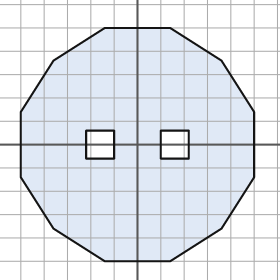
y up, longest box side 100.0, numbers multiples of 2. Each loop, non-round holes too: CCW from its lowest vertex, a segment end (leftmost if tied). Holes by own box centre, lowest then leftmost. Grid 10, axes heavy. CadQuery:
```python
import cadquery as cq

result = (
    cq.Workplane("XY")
    .moveTo(-14.0, -50.0)
    .lineTo(14.0, -50.0)
    .lineTo(36.0, -36.0)
    .lineTo(50.0, -14.0)
    .lineTo(50.0, 14.0)
    .lineTo(36.0, 36.0)
    .lineTo(14.0, 50.0)
    .lineTo(-14.0, 50.0)
    .lineTo(-36.0, 36.0)
    .lineTo(-50.0, 14.0)
    .lineTo(-50.0, -14.0)
    .lineTo(-36.0, -36.0)
    .close()
    .moveTo(-22.0, -6.0)
    .lineTo(-10.0, -6.0)
    .lineTo(-10.0, 6.0)
    .lineTo(-22.0, 6.0)
    .close()
    .moveTo(10.0, -6.0)
    .lineTo(22.0, -6.0)
    .lineTo(22.0, 6.0)
    .lineTo(10.0, 6.0)
    .close()
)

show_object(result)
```